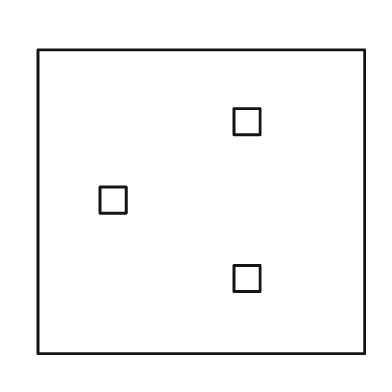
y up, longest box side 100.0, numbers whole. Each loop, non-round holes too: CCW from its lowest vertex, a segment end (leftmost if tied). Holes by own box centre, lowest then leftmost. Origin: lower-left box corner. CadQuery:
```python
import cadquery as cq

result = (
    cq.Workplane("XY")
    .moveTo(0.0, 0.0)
    .lineTo(100.0, 0.0)
    .lineTo(100.0, 93.0)
    .lineTo(0.0, 93.0)
    .close()
    .moveTo(60.0, 19.0)
    .lineTo(68.0, 19.0)
    .lineTo(68.0, 27.0)
    .lineTo(60.0, 27.0)
    .close()
    .moveTo(19.0, 43.0)
    .lineTo(27.0, 43.0)
    .lineTo(27.0, 51.0)
    .lineTo(19.0, 51.0)
    .close()
    .moveTo(60.0, 67.0)
    .lineTo(68.0, 67.0)
    .lineTo(68.0, 75.0)
    .lineTo(60.0, 75.0)
    .close()
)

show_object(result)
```